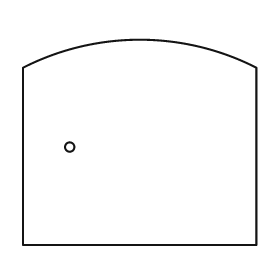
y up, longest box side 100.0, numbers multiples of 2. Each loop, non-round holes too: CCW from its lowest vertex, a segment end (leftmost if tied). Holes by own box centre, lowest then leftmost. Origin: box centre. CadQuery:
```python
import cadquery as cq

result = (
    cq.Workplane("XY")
    .moveTo(-50.0, -44.0)
    .lineTo(50.0, -44.0)
    .lineTo(50.0, 32.0)
    .threePointArc((0.0, 44.0), (-50.0, 32.0))
    .close()
    .moveTo(-30.0, -2.0)
    .circle(2.0)
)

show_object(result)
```